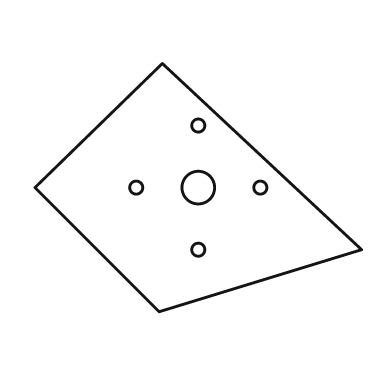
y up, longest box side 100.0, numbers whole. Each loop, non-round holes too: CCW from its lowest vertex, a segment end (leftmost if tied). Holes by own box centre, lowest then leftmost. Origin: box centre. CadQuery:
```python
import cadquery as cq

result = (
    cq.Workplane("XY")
    .moveTo(-12.0, -38.0)
    .lineTo(50.0, -19.0)
    .lineTo(-11.0, 38.0)
    .lineTo(-50.0, 0.0)
    .close()
    .moveTo(0.0, -19.0)
    .circle(2.0)
    .moveTo(-19.0, 0.0)
    .circle(2.0)
    .moveTo(0.0, 0.0)
    .circle(5.0)
    .moveTo(19.0, 0.0)
    .circle(2.0)
    .moveTo(0.0, 19.0)
    .circle(2.0)
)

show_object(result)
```